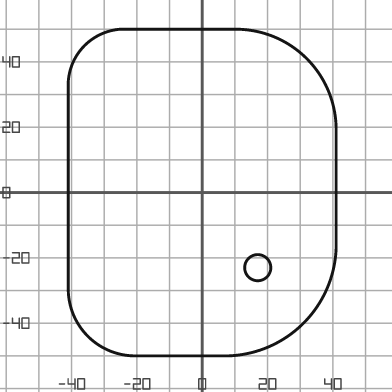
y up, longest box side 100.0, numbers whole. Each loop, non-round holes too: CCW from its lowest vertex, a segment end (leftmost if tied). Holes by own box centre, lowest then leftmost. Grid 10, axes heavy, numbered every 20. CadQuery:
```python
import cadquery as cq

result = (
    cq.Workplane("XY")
    .moveTo(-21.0, -50.0)
    .lineTo(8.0, -50.0)
    .threePointArc((31.0, -40.0), (41.0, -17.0))
    .lineTo(41.0, 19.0)
    .threePointArc((32.0, 41.0), (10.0, 50.0))
    .lineTo(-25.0, 50.0)
    .threePointArc((-36.0, 45.0), (-41.0, 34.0))
    .lineTo(-41.0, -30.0)
    .threePointArc((-35.0, -44.0), (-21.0, -50.0))
    .close()
    .moveTo(17.0, -23.0)
    .circle(4.0)
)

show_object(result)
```